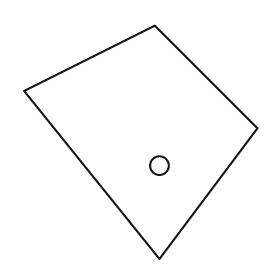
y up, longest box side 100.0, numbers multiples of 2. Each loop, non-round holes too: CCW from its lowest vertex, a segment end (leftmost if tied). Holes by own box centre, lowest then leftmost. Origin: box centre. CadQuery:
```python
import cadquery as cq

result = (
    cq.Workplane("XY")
    .moveTo(8.0, -50.0)
    .lineTo(50.0, 6.0)
    .lineTo(6.0, 50.0)
    .lineTo(-50.0, 22.0)
    .close()
    .moveTo(8.0, -10.0)
    .circle(4.0)
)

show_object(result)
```